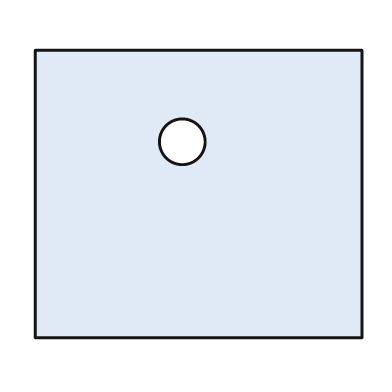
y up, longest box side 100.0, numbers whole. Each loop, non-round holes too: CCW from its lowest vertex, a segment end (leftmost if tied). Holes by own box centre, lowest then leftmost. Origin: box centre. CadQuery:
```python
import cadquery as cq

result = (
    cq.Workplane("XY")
    .moveTo(-50.0, -44.0)
    .lineTo(50.0, -44.0)
    .lineTo(50.0, 44.0)
    .lineTo(-50.0, 44.0)
    .close()
    .moveTo(-5.0, 16.0)
    .circle(7.0)
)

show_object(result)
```